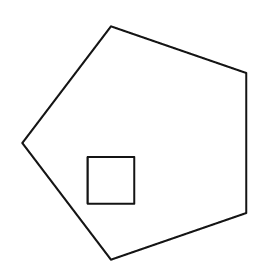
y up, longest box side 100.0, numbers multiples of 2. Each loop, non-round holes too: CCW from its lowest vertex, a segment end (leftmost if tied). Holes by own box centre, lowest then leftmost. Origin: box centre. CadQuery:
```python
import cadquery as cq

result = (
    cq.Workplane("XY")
    .moveTo(-10.0, -50.0)
    .lineTo(48.0, -30.0)
    .lineTo(48.0, 30.0)
    .lineTo(-10.0, 50.0)
    .lineTo(-48.0, 0.0)
    .close()
    .moveTo(-20.0, -26.0)
    .lineTo(0.0, -26.0)
    .lineTo(0.0, -6.0)
    .lineTo(-20.0, -6.0)
    .close()
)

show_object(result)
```